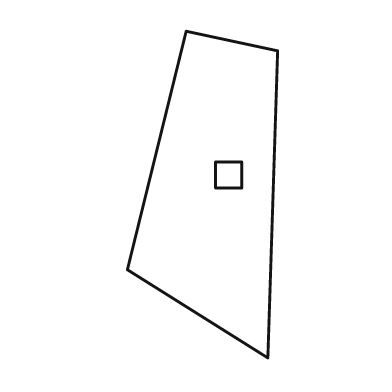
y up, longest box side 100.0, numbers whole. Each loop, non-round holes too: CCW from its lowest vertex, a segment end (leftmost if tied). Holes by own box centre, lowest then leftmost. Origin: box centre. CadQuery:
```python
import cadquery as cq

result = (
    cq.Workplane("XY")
    .moveTo(20.0, -50.0)
    .lineTo(23.0, 44.0)
    .lineTo(-5.0, 50.0)
    .lineTo(-23.0, -23.0)
    .close()
    .moveTo(4.0, 2.0)
    .lineTo(12.0, 2.0)
    .lineTo(12.0, 10.0)
    .lineTo(4.0, 10.0)
    .close()
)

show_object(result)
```